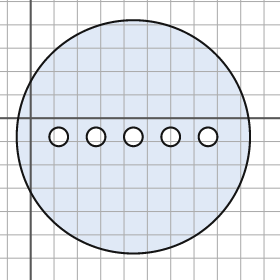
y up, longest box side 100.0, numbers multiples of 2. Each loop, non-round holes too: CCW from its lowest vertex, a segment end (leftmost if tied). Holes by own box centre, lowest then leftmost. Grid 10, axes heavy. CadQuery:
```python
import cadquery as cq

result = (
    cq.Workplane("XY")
    .moveTo(44.0, -8.0)
    .circle(50.0)
    .moveTo(12.0, -8.0)
    .circle(4.0)
    .moveTo(28.0, -8.0)
    .circle(4.0)
    .moveTo(44.0, -8.0)
    .circle(4.0)
    .moveTo(60.0, -8.0)
    .circle(4.0)
    .moveTo(76.0, -8.0)
    .circle(4.0)
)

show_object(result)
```